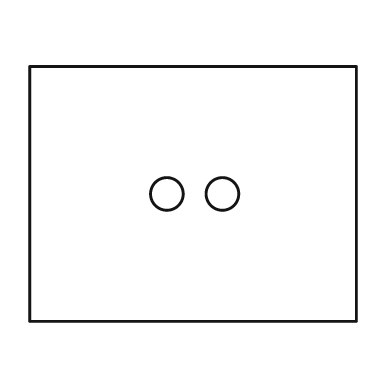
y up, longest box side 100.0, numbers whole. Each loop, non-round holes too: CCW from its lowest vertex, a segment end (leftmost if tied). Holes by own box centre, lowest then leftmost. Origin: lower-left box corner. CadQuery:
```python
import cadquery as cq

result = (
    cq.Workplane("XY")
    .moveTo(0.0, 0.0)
    .lineTo(100.0, 0.0)
    .lineTo(100.0, 78.0)
    .lineTo(0.0, 78.0)
    .close()
    .moveTo(42.0, 39.0)
    .circle(5.0)
    .moveTo(59.0, 39.0)
    .circle(5.0)
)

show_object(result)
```